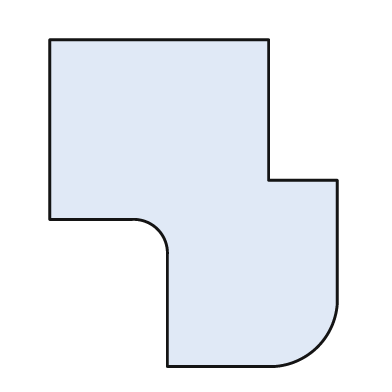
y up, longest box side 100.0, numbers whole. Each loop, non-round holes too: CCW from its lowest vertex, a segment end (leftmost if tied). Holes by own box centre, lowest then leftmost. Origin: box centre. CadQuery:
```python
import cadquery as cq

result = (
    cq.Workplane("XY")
    .moveTo(-8.0, -50.0)
    .lineTo(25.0, -50.0)
    .threePointArc((38.0, -44.0), (44.0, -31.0))
    .lineTo(44.0, 7.0)
    .lineTo(23.0, 7.0)
    .lineTo(23.0, 50.0)
    .lineTo(-44.0, 50.0)
    .lineTo(-44.0, -5.0)
    .lineTo(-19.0, -5.0)
    .threePointArc((-11.0, -8.0), (-8.0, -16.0))
    .close()
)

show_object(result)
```